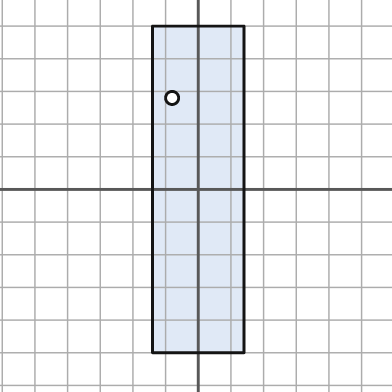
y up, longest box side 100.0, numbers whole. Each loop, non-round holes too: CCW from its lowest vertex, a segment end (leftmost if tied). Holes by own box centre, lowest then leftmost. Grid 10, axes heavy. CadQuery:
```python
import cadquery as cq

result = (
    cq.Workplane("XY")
    .moveTo(-14.0, -50.0)
    .lineTo(14.0, -50.0)
    .lineTo(14.0, 50.0)
    .lineTo(-14.0, 50.0)
    .close()
    .moveTo(-8.0, 28.0)
    .circle(2.0)
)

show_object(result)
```